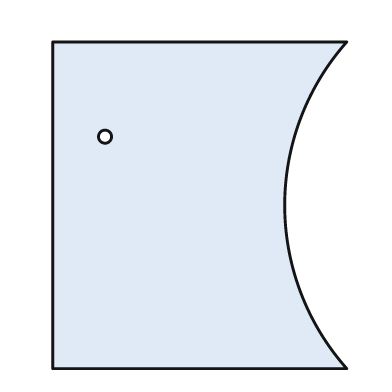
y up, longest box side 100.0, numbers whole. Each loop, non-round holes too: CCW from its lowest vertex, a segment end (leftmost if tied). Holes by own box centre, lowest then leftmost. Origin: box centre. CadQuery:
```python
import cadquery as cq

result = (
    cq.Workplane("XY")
    .moveTo(-45.0, -50.0)
    .lineTo(45.0, -50.0)
    .threePointArc((26.0, 0.0), (45.0, 50.0))
    .lineTo(-45.0, 50.0)
    .close()
    .moveTo(-29.0, 21.0)
    .circle(2.0)
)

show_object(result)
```